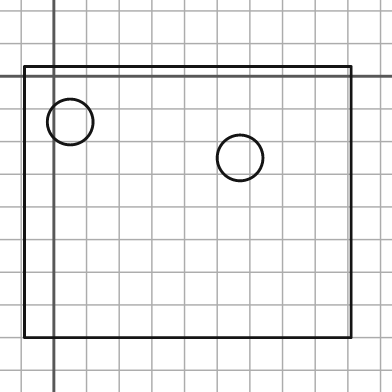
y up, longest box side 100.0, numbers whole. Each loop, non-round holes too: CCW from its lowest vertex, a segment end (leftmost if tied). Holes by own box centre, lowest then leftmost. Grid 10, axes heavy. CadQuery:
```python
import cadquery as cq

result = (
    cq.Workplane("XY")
    .moveTo(-9.0, -80.0)
    .lineTo(91.0, -80.0)
    .lineTo(91.0, 3.0)
    .lineTo(-9.0, 3.0)
    .close()
    .moveTo(57.0, -25.0)
    .circle(7.0)
    .moveTo(5.0, -14.0)
    .circle(7.0)
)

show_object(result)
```